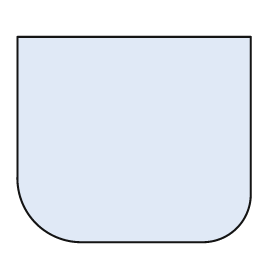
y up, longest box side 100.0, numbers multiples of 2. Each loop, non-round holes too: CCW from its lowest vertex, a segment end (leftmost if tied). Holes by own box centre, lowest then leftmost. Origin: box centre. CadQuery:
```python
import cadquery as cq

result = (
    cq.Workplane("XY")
    .moveTo(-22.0, -44.0)
    .lineTo(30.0, -44.0)
    .threePointArc((44.0, -38.0), (50.0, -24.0))
    .lineTo(50.0, 44.0)
    .lineTo(-50.0, 44.0)
    .lineTo(-50.0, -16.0)
    .threePointArc((-42.0, -36.0), (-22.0, -44.0))
    .close()
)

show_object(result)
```